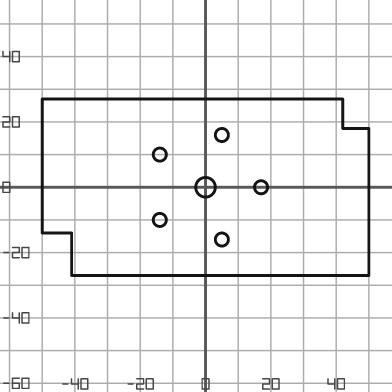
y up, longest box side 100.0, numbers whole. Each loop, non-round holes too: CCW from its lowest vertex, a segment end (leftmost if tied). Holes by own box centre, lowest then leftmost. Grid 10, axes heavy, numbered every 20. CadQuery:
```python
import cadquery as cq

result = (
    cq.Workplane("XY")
    .moveTo(-41.0, -27.0)
    .lineTo(50.0, -27.0)
    .lineTo(50.0, 18.0)
    .lineTo(42.0, 18.0)
    .lineTo(42.0, 27.0)
    .lineTo(-50.0, 27.0)
    .lineTo(-50.0, -14.0)
    .lineTo(-41.0, -14.0)
    .close()
    .moveTo(5.0, -16.0)
    .circle(2.0)
    .moveTo(-14.0, -10.0)
    .circle(2.0)
    .moveTo(0.0, 0.0)
    .circle(3.0)
    .moveTo(17.0, 0.0)
    .circle(2.0)
    .moveTo(-14.0, 10.0)
    .circle(2.0)
    .moveTo(5.0, 16.0)
    .circle(2.0)
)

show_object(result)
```